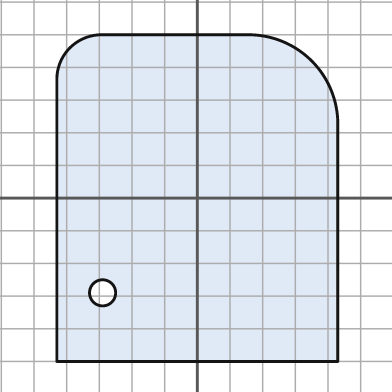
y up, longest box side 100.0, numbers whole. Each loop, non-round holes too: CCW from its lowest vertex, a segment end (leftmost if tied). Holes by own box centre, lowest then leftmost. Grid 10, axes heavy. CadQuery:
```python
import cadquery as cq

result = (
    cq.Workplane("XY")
    .moveTo(-43.0, -50.0)
    .lineTo(43.0, -50.0)
    .lineTo(43.0, 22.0)
    .threePointArc((35.0, 42.0), (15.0, 50.0))
    .lineTo(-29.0, 50.0)
    .threePointArc((-39.0, 46.0), (-43.0, 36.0))
    .close()
    .moveTo(-29.0, -29.0)
    .circle(4.0)
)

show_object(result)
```